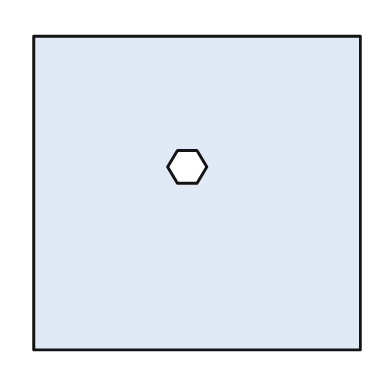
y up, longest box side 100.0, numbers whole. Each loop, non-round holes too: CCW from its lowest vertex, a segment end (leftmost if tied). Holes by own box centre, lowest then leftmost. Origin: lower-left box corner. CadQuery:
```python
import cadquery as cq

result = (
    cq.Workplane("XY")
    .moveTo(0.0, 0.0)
    .lineTo(100.0, 0.0)
    .lineTo(100.0, 96.0)
    .lineTo(0.0, 96.0)
    .close()
    .moveTo(44.0, 51.0)
    .lineTo(50.0, 51.0)
    .lineTo(53.0, 56.0)
    .lineTo(50.0, 61.0)
    .lineTo(44.0, 61.0)
    .lineTo(41.0, 56.0)
    .close()
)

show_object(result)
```